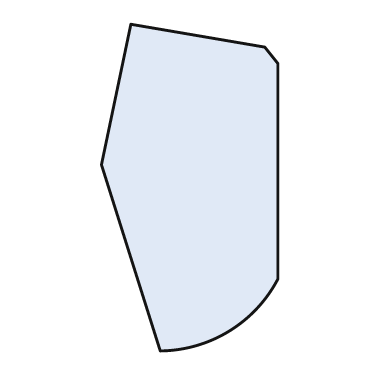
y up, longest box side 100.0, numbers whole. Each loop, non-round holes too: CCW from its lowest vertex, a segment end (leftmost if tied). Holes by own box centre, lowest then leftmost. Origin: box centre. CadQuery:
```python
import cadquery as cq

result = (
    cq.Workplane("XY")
    .moveTo(-9.0, -50.0)
    .threePointArc((12.0, -44.0), (27.0, -28.0))
    .lineTo(27.0, 38.0)
    .lineTo(23.0, 43.0)
    .lineTo(-18.0, 50.0)
    .lineTo(-27.0, 7.0)
    .close()
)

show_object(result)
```